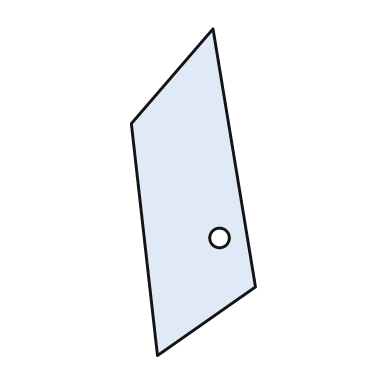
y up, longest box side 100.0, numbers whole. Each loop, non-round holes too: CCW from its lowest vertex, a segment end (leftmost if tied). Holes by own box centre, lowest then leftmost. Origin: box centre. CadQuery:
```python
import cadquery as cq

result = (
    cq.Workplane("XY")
    .moveTo(-11.0, -50.0)
    .lineTo(19.0, -29.0)
    .lineTo(6.0, 50.0)
    .lineTo(-19.0, 21.0)
    .close()
    .moveTo(8.0, -14.0)
    .circle(3.0)
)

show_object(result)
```